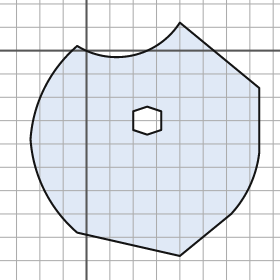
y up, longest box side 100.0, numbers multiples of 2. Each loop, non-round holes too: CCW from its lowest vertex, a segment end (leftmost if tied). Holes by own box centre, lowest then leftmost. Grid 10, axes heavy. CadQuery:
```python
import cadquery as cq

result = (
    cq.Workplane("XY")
    .moveTo(40.0, -88.0)
    .lineTo(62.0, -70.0)
    .threePointArc((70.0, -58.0), (74.0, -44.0))
    .lineTo(74.0, -16.0)
    .lineTo(40.0, 12.0)
    .threePointArc((20.0, -2.0), (-4.0, 2.0))
    .threePointArc((-18.0, -16.0), (-24.0, -38.0))
    .threePointArc((-18.0, -60.0), (-4.0, -78.0))
    .close()
    .moveTo(26.0, -36.0)
    .lineTo(32.0, -34.0)
    .lineTo(32.0, -26.0)
    .lineTo(26.0, -24.0)
    .lineTo(20.0, -26.0)
    .lineTo(20.0, -34.0)
    .close()
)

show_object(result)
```